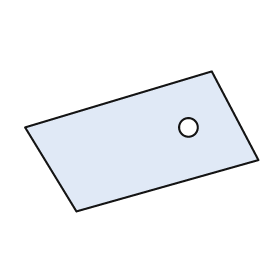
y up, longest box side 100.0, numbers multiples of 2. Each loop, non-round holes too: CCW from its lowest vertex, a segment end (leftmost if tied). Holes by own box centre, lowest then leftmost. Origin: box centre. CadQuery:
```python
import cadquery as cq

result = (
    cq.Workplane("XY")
    .moveTo(-28.0, -30.0)
    .lineTo(50.0, -8.0)
    .lineTo(30.0, 30.0)
    .lineTo(-50.0, 6.0)
    .close()
    .moveTo(20.0, 6.0)
    .circle(4.0)
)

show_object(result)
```